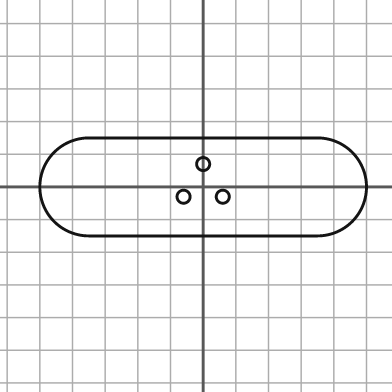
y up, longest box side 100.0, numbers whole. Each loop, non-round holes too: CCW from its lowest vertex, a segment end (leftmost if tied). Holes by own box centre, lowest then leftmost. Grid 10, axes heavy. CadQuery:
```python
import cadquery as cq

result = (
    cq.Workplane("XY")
    .moveTo(-35.0, -15.0)
    .lineTo(35.0, -15.0)
    .threePointArc((50.0, 0.0), (35.0, 15.0))
    .lineTo(-35.0, 15.0)
    .threePointArc((-50.0, 0.0), (-35.0, -15.0))
    .close()
    .moveTo(-6.0, -3.0)
    .circle(2.0)
    .moveTo(6.0, -3.0)
    .circle(2.0)
    .moveTo(0.0, 7.0)
    .circle(2.0)
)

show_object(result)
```